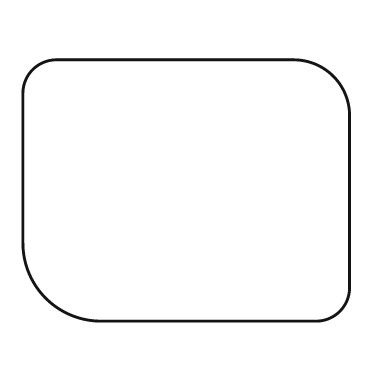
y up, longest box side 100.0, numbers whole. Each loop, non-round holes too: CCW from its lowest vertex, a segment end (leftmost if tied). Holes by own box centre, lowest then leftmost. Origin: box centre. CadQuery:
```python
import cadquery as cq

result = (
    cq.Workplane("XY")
    .moveTo(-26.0, -40.0)
    .lineTo(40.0, -40.0)
    .threePointArc((47.0, -37.0), (50.0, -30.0))
    .lineTo(50.0, 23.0)
    .threePointArc((45.0, 35.0), (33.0, 40.0))
    .lineTo(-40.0, 40.0)
    .threePointArc((-47.0, 37.0), (-50.0, 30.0))
    .lineTo(-50.0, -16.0)
    .threePointArc((-43.0, -33.0), (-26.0, -40.0))
    .close()
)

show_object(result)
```